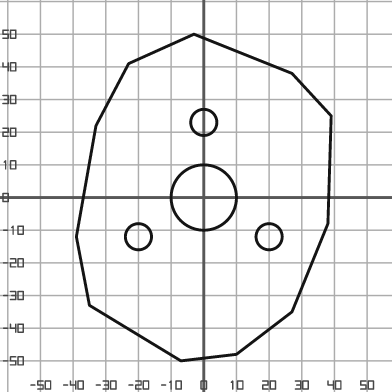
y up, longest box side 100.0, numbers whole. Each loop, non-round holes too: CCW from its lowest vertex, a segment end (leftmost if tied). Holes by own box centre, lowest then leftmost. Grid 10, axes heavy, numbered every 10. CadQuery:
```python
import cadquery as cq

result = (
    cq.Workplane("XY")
    .moveTo(-7.0, -50.0)
    .lineTo(10.0, -48.0)
    .lineTo(27.0, -35.0)
    .lineTo(38.0, -8.0)
    .lineTo(39.0, 25.0)
    .lineTo(27.0, 38.0)
    .lineTo(-3.0, 50.0)
    .lineTo(-23.0, 41.0)
    .lineTo(-33.0, 22.0)
    .lineTo(-39.0, -12.0)
    .lineTo(-35.0, -33.0)
    .close()
    .moveTo(-20.0, -12.0)
    .circle(4.0)
    .moveTo(20.0, -12.0)
    .circle(4.0)
    .moveTo(0.0, 0.0)
    .circle(10.0)
    .moveTo(0.0, 23.0)
    .circle(4.0)
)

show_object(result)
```